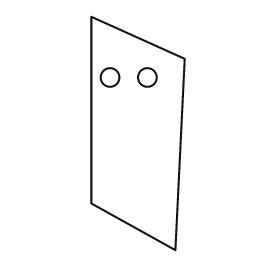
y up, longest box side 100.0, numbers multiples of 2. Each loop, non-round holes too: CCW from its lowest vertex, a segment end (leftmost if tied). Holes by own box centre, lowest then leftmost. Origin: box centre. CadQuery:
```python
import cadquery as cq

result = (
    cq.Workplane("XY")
    .moveTo(16.0, -50.0)
    .lineTo(20.0, 32.0)
    .lineTo(-20.0, 50.0)
    .lineTo(-20.0, -30.0)
    .close()
    .moveTo(-12.0, 24.0)
    .circle(4.0)
    .moveTo(4.0, 24.0)
    .circle(4.0)
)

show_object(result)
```